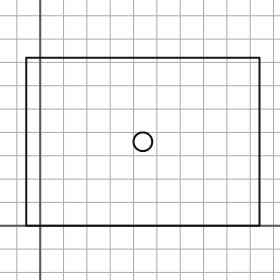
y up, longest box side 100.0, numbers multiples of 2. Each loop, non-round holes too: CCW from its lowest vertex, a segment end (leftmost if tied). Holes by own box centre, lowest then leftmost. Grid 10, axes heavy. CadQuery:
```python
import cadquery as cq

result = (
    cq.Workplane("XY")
    .moveTo(-6.0, 0.0)
    .lineTo(94.0, 0.0)
    .lineTo(94.0, 72.0)
    .lineTo(-6.0, 72.0)
    .close()
    .moveTo(44.0, 36.0)
    .circle(4.0)
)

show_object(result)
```